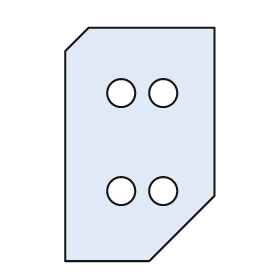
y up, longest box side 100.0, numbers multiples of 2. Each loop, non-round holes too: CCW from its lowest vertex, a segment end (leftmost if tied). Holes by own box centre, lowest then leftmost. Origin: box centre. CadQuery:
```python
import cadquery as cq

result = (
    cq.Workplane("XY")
    .moveTo(-32.0, -50.0)
    .lineTo(4.0, -50.0)
    .lineTo(32.0, -22.0)
    .lineTo(32.0, 50.0)
    .lineTo(-22.0, 50.0)
    .lineTo(-32.0, 40.0)
    .close()
    .moveTo(-8.0, -20.0)
    .circle(6.0)
    .moveTo(10.0, -20.0)
    .circle(6.0)
    .moveTo(-8.0, 22.0)
    .circle(6.0)
    .moveTo(10.0, 22.0)
    .circle(6.0)
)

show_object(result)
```